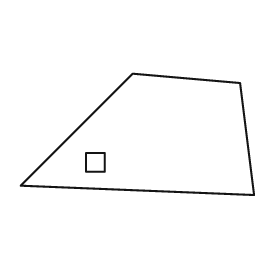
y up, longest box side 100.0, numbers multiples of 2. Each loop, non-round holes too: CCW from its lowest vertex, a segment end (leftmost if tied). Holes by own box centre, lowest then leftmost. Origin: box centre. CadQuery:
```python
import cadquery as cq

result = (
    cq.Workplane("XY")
    .moveTo(50.0, -26.0)
    .lineTo(44.0, 22.0)
    .lineTo(-2.0, 26.0)
    .lineTo(-50.0, -22.0)
    .close()
    .moveTo(-22.0, -16.0)
    .lineTo(-14.0, -16.0)
    .lineTo(-14.0, -8.0)
    .lineTo(-22.0, -8.0)
    .close()
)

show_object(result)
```